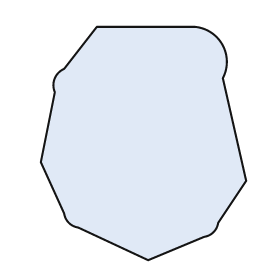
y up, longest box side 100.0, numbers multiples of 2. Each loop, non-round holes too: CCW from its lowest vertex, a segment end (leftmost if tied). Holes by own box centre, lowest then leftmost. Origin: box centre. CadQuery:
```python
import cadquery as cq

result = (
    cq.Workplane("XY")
    .moveTo(2.0, -50.0)
    .lineTo(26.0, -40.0)
    .threePointArc((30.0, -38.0), (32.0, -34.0))
    .lineTo(44.0, -16.0)
    .lineTo(34.0, 28.0)
    .threePointArc((34.0, 42.0), (22.0, 50.0))
    .lineTo(-20.0, 50.0)
    .lineTo(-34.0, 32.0)
    .threePointArc((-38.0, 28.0), (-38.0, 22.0))
    .lineTo(-44.0, -8.0)
    .lineTo(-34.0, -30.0)
    .threePointArc((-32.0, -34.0), (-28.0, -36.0))
    .close()
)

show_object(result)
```